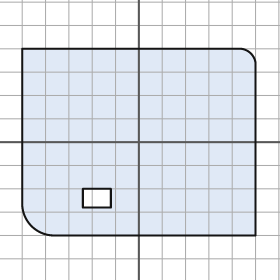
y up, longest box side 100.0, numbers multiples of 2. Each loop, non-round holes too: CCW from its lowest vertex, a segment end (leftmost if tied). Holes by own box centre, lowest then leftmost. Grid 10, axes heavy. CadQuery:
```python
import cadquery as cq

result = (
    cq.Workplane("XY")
    .moveTo(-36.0, -40.0)
    .lineTo(50.0, -40.0)
    .lineTo(50.0, 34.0)
    .threePointArc((48.0, 38.0), (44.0, 40.0))
    .lineTo(-50.0, 40.0)
    .lineTo(-50.0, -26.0)
    .threePointArc((-46.0, -36.0), (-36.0, -40.0))
    .close()
    .moveTo(-24.0, -28.0)
    .lineTo(-12.0, -28.0)
    .lineTo(-12.0, -20.0)
    .lineTo(-24.0, -20.0)
    .close()
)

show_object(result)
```